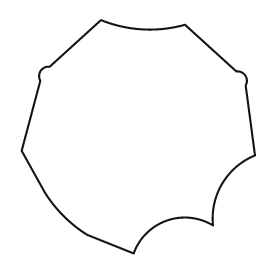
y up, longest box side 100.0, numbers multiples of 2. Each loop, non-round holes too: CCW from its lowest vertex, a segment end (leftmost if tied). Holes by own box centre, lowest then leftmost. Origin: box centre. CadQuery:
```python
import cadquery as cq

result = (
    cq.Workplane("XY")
    .moveTo(-2.0, -50.0)
    .threePointArc((12.0, -36.0), (32.0, -38.0))
    .threePointArc((36.0, -20.0), (50.0, -8.0))
    .lineTo(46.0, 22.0)
    .threePointArc((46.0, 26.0), (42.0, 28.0))
    .lineTo(20.0, 48.0)
    .threePointArc((2.0, 46.0), (-16.0, 50.0))
    .lineTo(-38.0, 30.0)
    .threePointArc((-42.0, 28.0), (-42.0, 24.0))
    .lineTo(-50.0, -6.0)
    .lineTo(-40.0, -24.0)
    .threePointArc((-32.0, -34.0), (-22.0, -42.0))
    .close()
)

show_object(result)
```